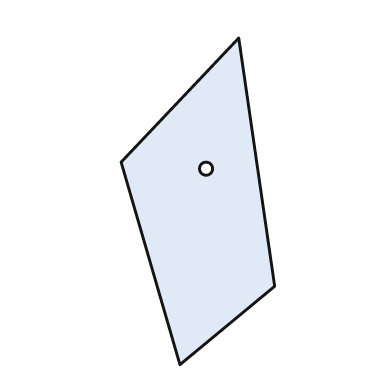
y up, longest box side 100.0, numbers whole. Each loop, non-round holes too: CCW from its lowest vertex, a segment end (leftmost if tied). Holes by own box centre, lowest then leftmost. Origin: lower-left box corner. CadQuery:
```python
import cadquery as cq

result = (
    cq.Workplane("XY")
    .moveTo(18.0, 0.0)
    .lineTo(47.0, 24.0)
    .lineTo(36.0, 100.0)
    .lineTo(0.0, 62.0)
    .close()
    .moveTo(26.0, 60.0)
    .circle(2.0)
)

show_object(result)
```